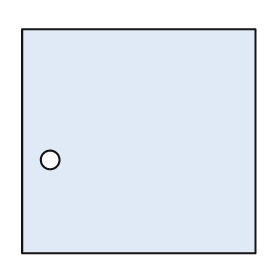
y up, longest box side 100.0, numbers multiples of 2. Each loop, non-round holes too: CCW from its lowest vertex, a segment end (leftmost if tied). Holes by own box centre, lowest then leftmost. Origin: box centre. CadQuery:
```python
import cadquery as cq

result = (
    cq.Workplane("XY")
    .moveTo(-50.0, -48.0)
    .lineTo(50.0, -48.0)
    .lineTo(50.0, 48.0)
    .lineTo(-50.0, 48.0)
    .close()
    .moveTo(-38.0, -8.0)
    .circle(4.0)
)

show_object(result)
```